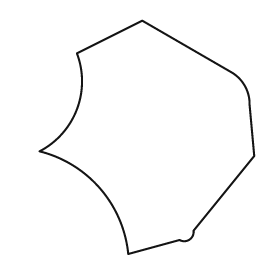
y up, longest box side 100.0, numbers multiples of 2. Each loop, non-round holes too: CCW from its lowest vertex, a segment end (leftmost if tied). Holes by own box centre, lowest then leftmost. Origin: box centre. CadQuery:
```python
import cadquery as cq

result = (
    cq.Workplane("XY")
    .moveTo(-8.0, -50.0)
    .lineTo(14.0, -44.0)
    .threePointArc((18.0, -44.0), (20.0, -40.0))
    .lineTo(46.0, -8.0)
    .lineTo(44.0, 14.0)
    .threePointArc((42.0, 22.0), (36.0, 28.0))
    .lineTo(-2.0, 50.0)
    .lineTo(-30.0, 36.0)
    .threePointArc((-30.0, 12.0), (-46.0, -6.0))
    .threePointArc((-20.0, -22.0), (-8.0, -50.0))
    .close()
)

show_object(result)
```